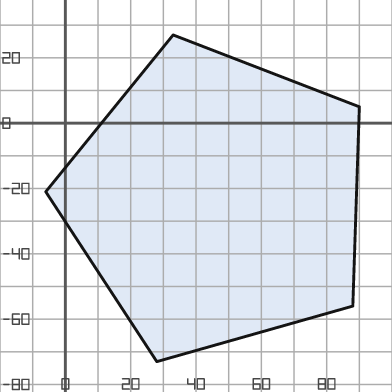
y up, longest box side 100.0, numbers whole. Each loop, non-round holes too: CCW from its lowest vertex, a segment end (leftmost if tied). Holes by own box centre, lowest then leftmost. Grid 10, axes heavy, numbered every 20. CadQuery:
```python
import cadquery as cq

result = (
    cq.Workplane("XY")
    .moveTo(28.0, -73.0)
    .lineTo(88.0, -56.0)
    .lineTo(90.0, 5.0)
    .lineTo(33.0, 27.0)
    .lineTo(-6.0, -21.0)
    .close()
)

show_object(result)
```